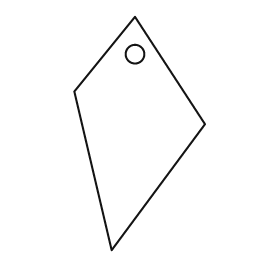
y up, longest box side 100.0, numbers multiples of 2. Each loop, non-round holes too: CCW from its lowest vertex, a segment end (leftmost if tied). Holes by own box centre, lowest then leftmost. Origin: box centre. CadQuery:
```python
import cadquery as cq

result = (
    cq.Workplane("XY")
    .moveTo(-12.0, -50.0)
    .lineTo(28.0, 4.0)
    .lineTo(-2.0, 50.0)
    .lineTo(-28.0, 18.0)
    .close()
    .moveTo(-2.0, 34.0)
    .circle(4.0)
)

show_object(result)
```